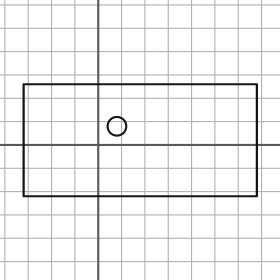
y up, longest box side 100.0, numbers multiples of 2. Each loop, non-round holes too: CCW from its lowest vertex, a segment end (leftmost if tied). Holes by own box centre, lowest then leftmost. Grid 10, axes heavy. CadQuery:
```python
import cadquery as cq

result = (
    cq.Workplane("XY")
    .moveTo(-32.0, -22.0)
    .lineTo(68.0, -22.0)
    .lineTo(68.0, 26.0)
    .lineTo(-32.0, 26.0)
    .close()
    .moveTo(8.0, 8.0)
    .circle(4.0)
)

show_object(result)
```